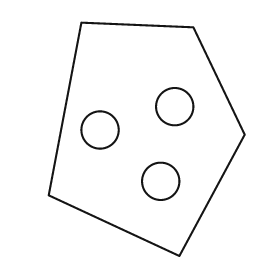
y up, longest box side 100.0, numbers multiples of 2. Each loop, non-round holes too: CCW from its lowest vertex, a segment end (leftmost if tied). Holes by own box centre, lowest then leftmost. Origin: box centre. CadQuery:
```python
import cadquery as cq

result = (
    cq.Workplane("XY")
    .moveTo(14.0, -50.0)
    .lineTo(42.0, 2.0)
    .lineTo(20.0, 48.0)
    .lineTo(-28.0, 50.0)
    .lineTo(-42.0, -24.0)
    .close()
    .moveTo(6.0, -18.0)
    .circle(8.0)
    .moveTo(-20.0, 4.0)
    .circle(8.0)
    .moveTo(12.0, 14.0)
    .circle(8.0)
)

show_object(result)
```